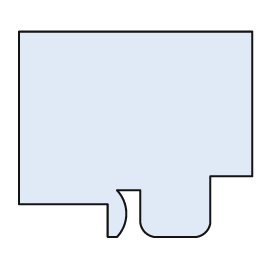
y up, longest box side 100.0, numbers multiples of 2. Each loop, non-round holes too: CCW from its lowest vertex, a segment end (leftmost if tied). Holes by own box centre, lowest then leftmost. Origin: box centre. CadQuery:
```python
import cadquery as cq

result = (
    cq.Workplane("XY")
    .moveTo(-12.0, -44.0)
    .lineTo(-8.0, -44.0)
    .threePointArc((-4.0, -34.0), (-8.0, -24.0))
    .lineTo(2.0, -24.0)
    .lineTo(2.0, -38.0)
    .threePointArc((4.0, -42.0), (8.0, -44.0))
    .lineTo(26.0, -44.0)
    .threePointArc((30.0, -42.0), (32.0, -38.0))
    .lineTo(32.0, -18.0)
    .lineTo(50.0, -18.0)
    .lineTo(50.0, 44.0)
    .lineTo(-50.0, 44.0)
    .lineTo(-50.0, -30.0)
    .lineTo(-12.0, -30.0)
    .close()
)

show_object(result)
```